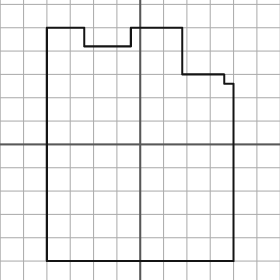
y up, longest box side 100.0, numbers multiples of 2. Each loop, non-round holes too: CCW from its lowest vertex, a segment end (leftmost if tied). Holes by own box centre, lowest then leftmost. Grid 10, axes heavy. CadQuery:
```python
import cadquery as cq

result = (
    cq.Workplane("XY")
    .moveTo(-40.0, -50.0)
    .lineTo(40.0, -50.0)
    .lineTo(40.0, 26.0)
    .lineTo(36.0, 26.0)
    .lineTo(36.0, 30.0)
    .lineTo(18.0, 30.0)
    .lineTo(18.0, 50.0)
    .lineTo(-4.0, 50.0)
    .lineTo(-4.0, 42.0)
    .lineTo(-24.0, 42.0)
    .lineTo(-24.0, 50.0)
    .lineTo(-40.0, 50.0)
    .close()
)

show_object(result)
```